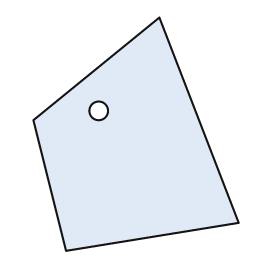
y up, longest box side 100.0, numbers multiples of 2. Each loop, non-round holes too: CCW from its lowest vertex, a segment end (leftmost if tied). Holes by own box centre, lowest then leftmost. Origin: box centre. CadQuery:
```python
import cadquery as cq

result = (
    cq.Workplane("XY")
    .moveTo(-30.0, -50.0)
    .lineTo(44.0, -38.0)
    .lineTo(10.0, 50.0)
    .lineTo(-44.0, 6.0)
    .close()
    .moveTo(-16.0, 10.0)
    .circle(4.0)
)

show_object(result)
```